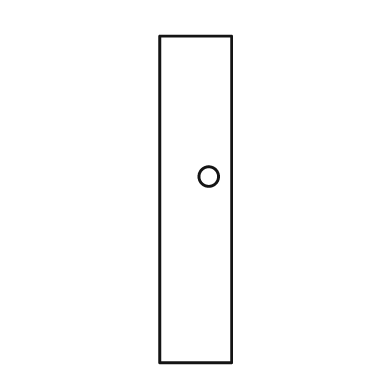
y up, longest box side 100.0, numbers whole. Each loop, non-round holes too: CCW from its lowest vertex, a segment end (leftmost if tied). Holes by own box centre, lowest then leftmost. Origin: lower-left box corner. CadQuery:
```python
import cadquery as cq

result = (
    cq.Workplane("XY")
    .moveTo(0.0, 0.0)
    .lineTo(22.0, 0.0)
    .lineTo(22.0, 100.0)
    .lineTo(0.0, 100.0)
    .close()
    .moveTo(15.0, 57.0)
    .circle(3.0)
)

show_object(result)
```